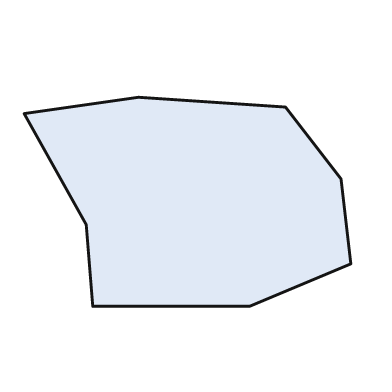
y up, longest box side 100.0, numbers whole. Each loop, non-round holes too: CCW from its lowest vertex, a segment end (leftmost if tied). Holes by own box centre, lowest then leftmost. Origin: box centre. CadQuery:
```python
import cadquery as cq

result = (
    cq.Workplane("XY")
    .moveTo(-29.0, -32.0)
    .lineTo(19.0, -32.0)
    .lineTo(50.0, -19.0)
    .lineTo(47.0, 7.0)
    .lineTo(30.0, 29.0)
    .lineTo(-15.0, 32.0)
    .lineTo(-50.0, 27.0)
    .lineTo(-31.0, -7.0)
    .close()
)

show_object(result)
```